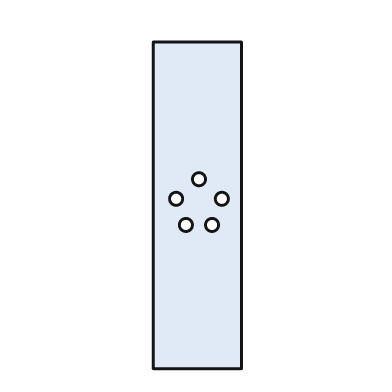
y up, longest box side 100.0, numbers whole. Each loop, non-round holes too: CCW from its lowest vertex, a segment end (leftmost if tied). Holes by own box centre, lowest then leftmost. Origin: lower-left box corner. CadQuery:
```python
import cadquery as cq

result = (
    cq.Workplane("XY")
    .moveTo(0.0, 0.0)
    .lineTo(27.0, 0.0)
    .lineTo(27.0, 100.0)
    .lineTo(0.0, 100.0)
    .close()
    .moveTo(10.0, 44.0)
    .circle(2.0)
    .moveTo(18.0, 44.0)
    .circle(2.0)
    .moveTo(7.0, 52.0)
    .circle(2.0)
    .moveTo(21.0, 52.0)
    .circle(2.0)
    .moveTo(14.0, 58.0)
    .circle(2.0)
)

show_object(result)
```